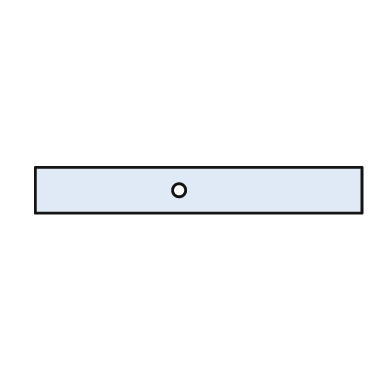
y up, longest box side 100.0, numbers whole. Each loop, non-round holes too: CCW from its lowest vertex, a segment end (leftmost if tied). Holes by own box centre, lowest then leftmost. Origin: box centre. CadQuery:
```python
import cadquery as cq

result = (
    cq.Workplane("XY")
    .moveTo(-50.0, -7.0)
    .lineTo(50.0, -7.0)
    .lineTo(50.0, 7.0)
    .lineTo(-50.0, 7.0)
    .close()
    .moveTo(-6.0, 0.0)
    .circle(2.0)
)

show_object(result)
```